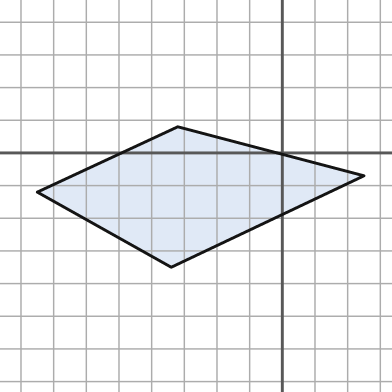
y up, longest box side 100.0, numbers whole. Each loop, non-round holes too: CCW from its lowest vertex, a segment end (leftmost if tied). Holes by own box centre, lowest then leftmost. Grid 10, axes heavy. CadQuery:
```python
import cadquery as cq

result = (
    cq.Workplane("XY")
    .moveTo(-34.0, -35.0)
    .lineTo(25.0, -7.0)
    .lineTo(-32.0, 8.0)
    .lineTo(-75.0, -12.0)
    .close()
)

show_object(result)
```